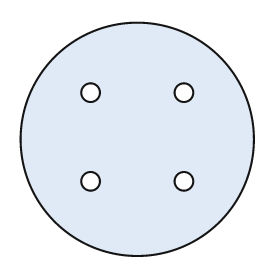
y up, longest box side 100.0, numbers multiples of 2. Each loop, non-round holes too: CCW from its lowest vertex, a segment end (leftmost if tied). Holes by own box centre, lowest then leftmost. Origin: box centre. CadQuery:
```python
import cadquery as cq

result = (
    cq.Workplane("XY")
    .moveTo(0.0, 0.0)
    .circle(50.0)
    .moveTo(-20.0, -18.0)
    .circle(4.0)
    .moveTo(20.0, -18.0)
    .circle(4.0)
    .moveTo(-20.0, 20.0)
    .circle(4.0)
    .moveTo(20.0, 20.0)
    .circle(4.0)
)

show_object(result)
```